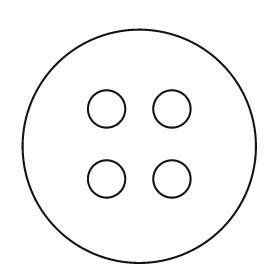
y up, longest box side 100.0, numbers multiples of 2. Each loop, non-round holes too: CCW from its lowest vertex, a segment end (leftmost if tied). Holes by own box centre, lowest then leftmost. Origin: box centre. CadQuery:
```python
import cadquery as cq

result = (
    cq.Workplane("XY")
    .moveTo(0.0, 0.0)
    .circle(50.0)
    .moveTo(-14.0, -14.0)
    .circle(8.0)
    .moveTo(14.0, -14.0)
    .circle(8.0)
    .moveTo(-14.0, 16.0)
    .circle(8.0)
    .moveTo(14.0, 16.0)
    .circle(8.0)
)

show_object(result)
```